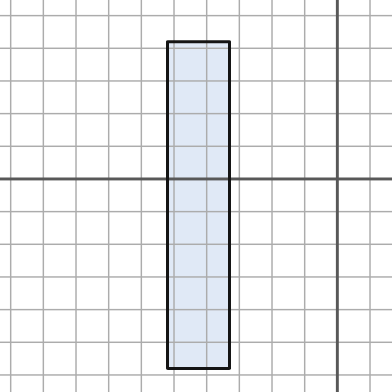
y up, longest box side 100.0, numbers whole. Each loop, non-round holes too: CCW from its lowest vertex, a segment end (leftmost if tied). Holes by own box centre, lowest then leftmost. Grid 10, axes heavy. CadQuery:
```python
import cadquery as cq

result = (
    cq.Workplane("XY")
    .moveTo(-52.0, -58.0)
    .lineTo(-33.0, -58.0)
    .lineTo(-33.0, 42.0)
    .lineTo(-52.0, 42.0)
    .close()
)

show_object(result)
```